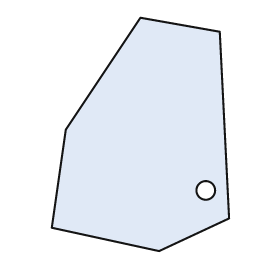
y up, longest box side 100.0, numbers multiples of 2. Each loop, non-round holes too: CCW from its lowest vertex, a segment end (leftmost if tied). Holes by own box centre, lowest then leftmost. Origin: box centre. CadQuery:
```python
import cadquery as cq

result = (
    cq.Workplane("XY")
    .moveTo(8.0, -50.0)
    .lineTo(38.0, -36.0)
    .lineTo(34.0, 44.0)
    .lineTo(0.0, 50.0)
    .lineTo(-32.0, 2.0)
    .lineTo(-38.0, -40.0)
    .close()
    .moveTo(28.0, -24.0)
    .circle(4.0)
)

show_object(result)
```